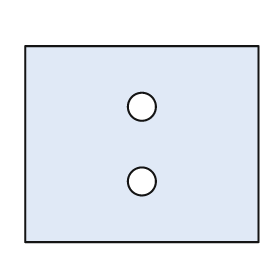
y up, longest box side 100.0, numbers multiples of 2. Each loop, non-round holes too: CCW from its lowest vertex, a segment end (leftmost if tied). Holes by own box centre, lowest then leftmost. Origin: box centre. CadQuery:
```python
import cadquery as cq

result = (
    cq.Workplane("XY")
    .moveTo(-50.0, -42.0)
    .lineTo(50.0, -42.0)
    .lineTo(50.0, 42.0)
    .lineTo(-50.0, 42.0)
    .close()
    .moveTo(0.0, -16.0)
    .circle(6.0)
    .moveTo(0.0, 16.0)
    .circle(6.0)
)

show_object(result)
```